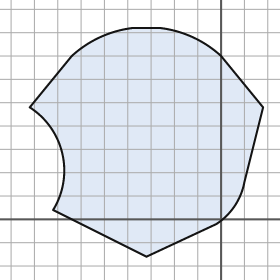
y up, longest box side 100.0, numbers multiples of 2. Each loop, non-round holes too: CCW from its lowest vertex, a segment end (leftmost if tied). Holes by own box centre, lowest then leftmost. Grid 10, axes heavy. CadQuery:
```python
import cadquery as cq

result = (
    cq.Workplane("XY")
    .moveTo(-32.0, -16.0)
    .lineTo(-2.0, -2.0)
    .threePointArc((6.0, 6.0), (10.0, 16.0))
    .lineTo(18.0, 48.0)
    .lineTo(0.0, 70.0)
    .threePointArc((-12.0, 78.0), (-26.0, 82.0))
    .lineTo(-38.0, 82.0)
    .threePointArc((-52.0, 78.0), (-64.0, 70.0))
    .lineTo(-82.0, 48.0)
    .threePointArc((-68.0, 28.0), (-72.0, 4.0))
    .close()
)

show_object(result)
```